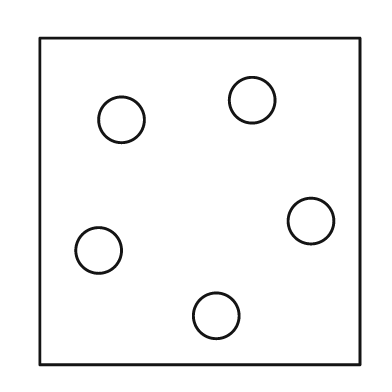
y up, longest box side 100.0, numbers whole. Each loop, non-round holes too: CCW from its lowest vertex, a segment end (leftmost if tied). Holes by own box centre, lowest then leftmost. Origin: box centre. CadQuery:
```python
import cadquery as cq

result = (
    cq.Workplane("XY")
    .moveTo(-49.0, -50.0)
    .lineTo(49.0, -50.0)
    .lineTo(49.0, 50.0)
    .lineTo(-49.0, 50.0)
    .close()
    .moveTo(5.0, -35.0)
    .circle(7.0)
    .moveTo(-31.0, -15.0)
    .circle(7.0)
    .moveTo(34.0, -6.0)
    .circle(7.0)
    .moveTo(-24.0, 25.0)
    .circle(7.0)
    .moveTo(16.0, 31.0)
    .circle(7.0)
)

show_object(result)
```